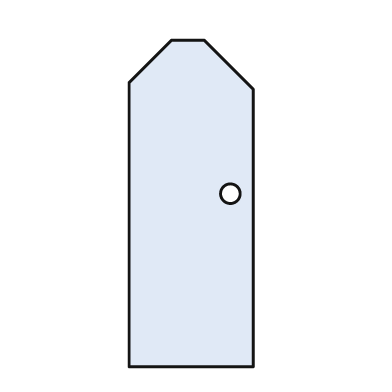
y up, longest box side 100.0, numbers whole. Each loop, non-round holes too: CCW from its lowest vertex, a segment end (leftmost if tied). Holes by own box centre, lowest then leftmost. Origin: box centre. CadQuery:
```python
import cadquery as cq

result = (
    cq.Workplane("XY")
    .moveTo(-19.0, -50.0)
    .lineTo(19.0, -50.0)
    .lineTo(19.0, 35.0)
    .lineTo(4.0, 50.0)
    .lineTo(-6.0, 50.0)
    .lineTo(-19.0, 37.0)
    .close()
    .moveTo(12.0, 3.0)
    .circle(3.0)
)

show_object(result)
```